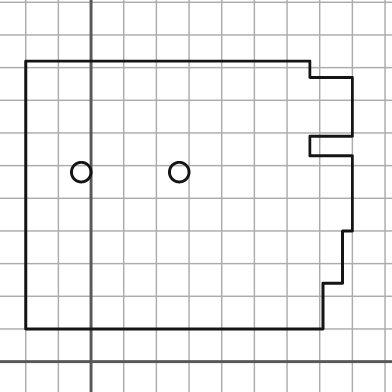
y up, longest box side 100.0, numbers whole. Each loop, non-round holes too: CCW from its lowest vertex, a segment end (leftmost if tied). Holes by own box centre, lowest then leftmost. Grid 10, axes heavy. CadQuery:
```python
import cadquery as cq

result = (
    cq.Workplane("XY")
    .moveTo(-20.0, 10.0)
    .lineTo(71.0, 10.0)
    .lineTo(71.0, 24.0)
    .lineTo(77.0, 24.0)
    .lineTo(77.0, 40.0)
    .lineTo(80.0, 40.0)
    .lineTo(80.0, 63.0)
    .lineTo(67.0, 63.0)
    .lineTo(67.0, 69.0)
    .lineTo(80.0, 69.0)
    .lineTo(80.0, 87.0)
    .lineTo(67.0, 87.0)
    .lineTo(67.0, 92.0)
    .lineTo(-20.0, 92.0)
    .close()
    .moveTo(-3.0, 58.0)
    .circle(3.0)
    .moveTo(27.0, 58.0)
    .circle(3.0)
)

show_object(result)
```